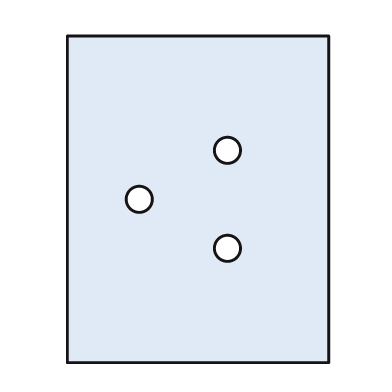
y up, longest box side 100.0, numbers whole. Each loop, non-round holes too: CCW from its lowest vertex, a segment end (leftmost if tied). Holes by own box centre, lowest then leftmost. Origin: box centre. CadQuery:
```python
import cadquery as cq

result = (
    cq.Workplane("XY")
    .moveTo(-40.0, -50.0)
    .lineTo(40.0, -50.0)
    .lineTo(40.0, 50.0)
    .lineTo(-40.0, 50.0)
    .close()
    .moveTo(9.0, -15.0)
    .circle(4.0)
    .moveTo(-18.0, 0.0)
    .circle(4.0)
    .moveTo(9.0, 15.0)
    .circle(4.0)
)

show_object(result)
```